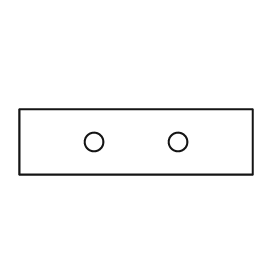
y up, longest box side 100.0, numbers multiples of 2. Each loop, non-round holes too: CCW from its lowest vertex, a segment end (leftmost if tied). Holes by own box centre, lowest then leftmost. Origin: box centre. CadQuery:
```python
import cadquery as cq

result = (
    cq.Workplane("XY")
    .moveTo(-50.0, -14.0)
    .lineTo(50.0, -14.0)
    .lineTo(50.0, 14.0)
    .lineTo(-50.0, 14.0)
    .close()
    .moveTo(-18.0, 0.0)
    .circle(4.0)
    .moveTo(18.0, 0.0)
    .circle(4.0)
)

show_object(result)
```